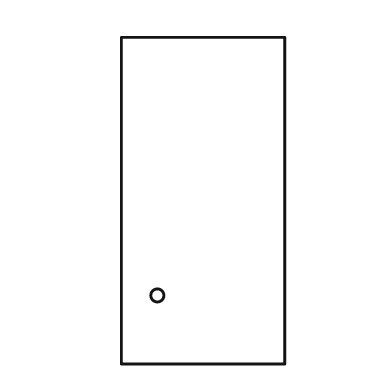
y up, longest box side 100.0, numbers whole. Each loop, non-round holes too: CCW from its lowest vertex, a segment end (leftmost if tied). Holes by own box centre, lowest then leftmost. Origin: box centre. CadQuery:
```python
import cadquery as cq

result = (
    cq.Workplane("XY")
    .moveTo(-25.0, -50.0)
    .lineTo(25.0, -50.0)
    .lineTo(25.0, 50.0)
    .lineTo(-25.0, 50.0)
    .close()
    .moveTo(-14.0, -29.0)
    .circle(2.0)
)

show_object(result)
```